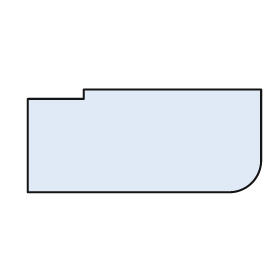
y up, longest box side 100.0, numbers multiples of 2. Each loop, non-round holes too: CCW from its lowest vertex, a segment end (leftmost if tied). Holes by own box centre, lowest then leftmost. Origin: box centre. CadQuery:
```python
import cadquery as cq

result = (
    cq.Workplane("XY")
    .moveTo(-50.0, -22.0)
    .lineTo(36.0, -22.0)
    .threePointArc((46.0, -18.0), (50.0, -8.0))
    .lineTo(50.0, 22.0)
    .lineTo(-26.0, 22.0)
    .lineTo(-26.0, 18.0)
    .lineTo(-50.0, 18.0)
    .close()
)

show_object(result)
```